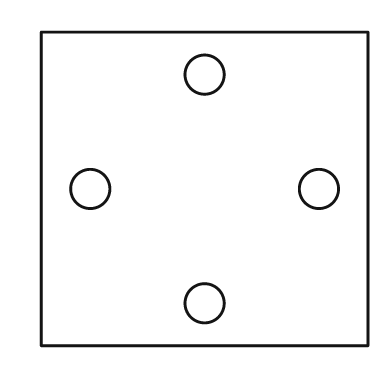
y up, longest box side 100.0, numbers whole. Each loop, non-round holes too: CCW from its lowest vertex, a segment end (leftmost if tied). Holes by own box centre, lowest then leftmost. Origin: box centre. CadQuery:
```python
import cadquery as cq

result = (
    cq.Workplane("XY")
    .moveTo(-50.0, -48.0)
    .lineTo(50.0, -48.0)
    .lineTo(50.0, 48.0)
    .lineTo(-50.0, 48.0)
    .close()
    .moveTo(0.0, -35.0)
    .circle(6.0)
    .moveTo(-35.0, 0.0)
    .circle(6.0)
    .moveTo(35.0, 0.0)
    .circle(6.0)
    .moveTo(0.0, 35.0)
    .circle(6.0)
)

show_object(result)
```